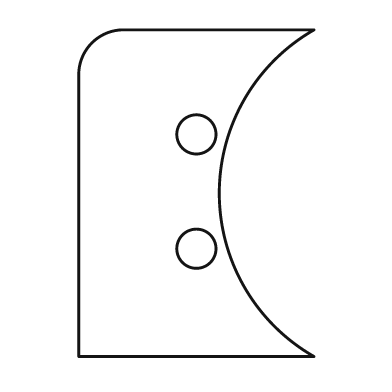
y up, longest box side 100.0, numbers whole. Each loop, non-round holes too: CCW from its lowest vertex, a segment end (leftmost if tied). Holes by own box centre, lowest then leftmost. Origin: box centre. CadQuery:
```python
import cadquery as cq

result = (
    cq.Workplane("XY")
    .moveTo(-36.0, -50.0)
    .lineTo(36.0, -50.0)
    .threePointArc((7.0, 0.0), (36.0, 50.0))
    .lineTo(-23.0, 50.0)
    .threePointArc((-32.0, 46.0), (-36.0, 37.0))
    .close()
    .moveTo(0.0, -17.0)
    .circle(6.0)
    .moveTo(0.0, 18.0)
    .circle(6.0)
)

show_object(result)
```